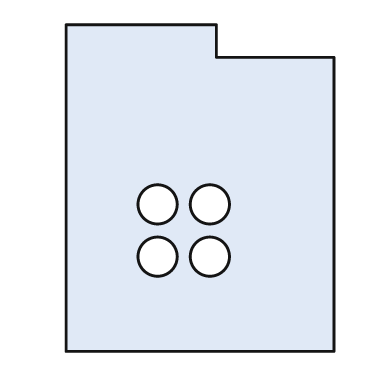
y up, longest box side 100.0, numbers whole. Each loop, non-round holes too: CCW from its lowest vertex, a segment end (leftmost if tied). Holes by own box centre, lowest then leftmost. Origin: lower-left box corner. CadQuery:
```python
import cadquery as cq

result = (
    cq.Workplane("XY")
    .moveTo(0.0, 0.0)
    .lineTo(82.0, 0.0)
    .lineTo(82.0, 90.0)
    .lineTo(46.0, 90.0)
    .lineTo(46.0, 100.0)
    .lineTo(0.0, 100.0)
    .close()
    .moveTo(28.0, 29.0)
    .circle(6.0)
    .moveTo(44.0, 29.0)
    .circle(6.0)
    .moveTo(28.0, 45.0)
    .circle(6.0)
    .moveTo(44.0, 45.0)
    .circle(6.0)
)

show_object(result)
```